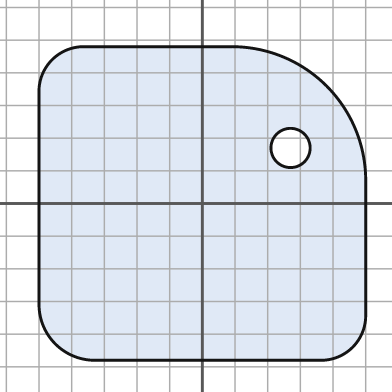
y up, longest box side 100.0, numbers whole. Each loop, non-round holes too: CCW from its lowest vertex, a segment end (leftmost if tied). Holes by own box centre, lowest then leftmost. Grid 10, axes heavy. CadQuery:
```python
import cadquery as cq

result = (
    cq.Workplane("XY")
    .moveTo(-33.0, -48.0)
    .lineTo(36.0, -48.0)
    .threePointArc((46.0, -44.0), (50.0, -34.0))
    .lineTo(50.0, 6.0)
    .threePointArc((38.0, 36.0), (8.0, 48.0))
    .lineTo(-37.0, 48.0)
    .threePointArc((-46.0, 44.0), (-50.0, 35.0))
    .lineTo(-50.0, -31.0)
    .threePointArc((-45.0, -43.0), (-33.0, -48.0))
    .close()
    .moveTo(27.0, 17.0)
    .circle(6.0)
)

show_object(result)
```